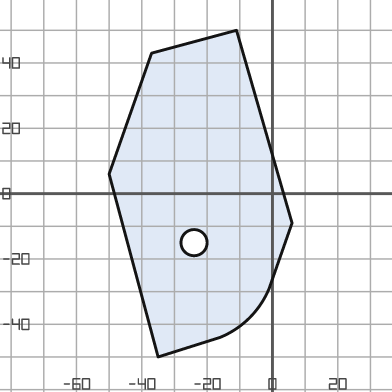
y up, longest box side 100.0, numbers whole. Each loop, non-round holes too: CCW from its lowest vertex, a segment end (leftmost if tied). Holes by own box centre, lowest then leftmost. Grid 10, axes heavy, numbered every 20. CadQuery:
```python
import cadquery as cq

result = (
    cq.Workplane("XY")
    .moveTo(-35.0, -50.0)
    .lineTo(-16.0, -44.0)
    .threePointArc((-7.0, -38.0), (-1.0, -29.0))
    .lineTo(6.0, -9.0)
    .lineTo(-11.0, 50.0)
    .lineTo(-37.0, 43.0)
    .lineTo(-50.0, 6.0)
    .close()
    .moveTo(-24.0, -15.0)
    .circle(4.0)
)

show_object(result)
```